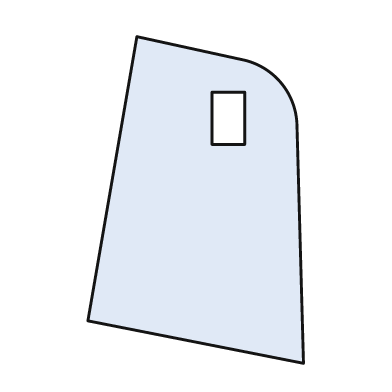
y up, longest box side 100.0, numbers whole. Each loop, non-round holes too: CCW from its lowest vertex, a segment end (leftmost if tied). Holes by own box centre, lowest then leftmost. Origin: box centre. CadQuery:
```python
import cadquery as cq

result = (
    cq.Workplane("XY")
    .moveTo(33.0, -50.0)
    .lineTo(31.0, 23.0)
    .threePointArc((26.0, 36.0), (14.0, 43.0))
    .lineTo(-18.0, 50.0)
    .lineTo(-33.0, -37.0)
    .close()
    .moveTo(5.0, 17.0)
    .lineTo(15.0, 17.0)
    .lineTo(15.0, 33.0)
    .lineTo(5.0, 33.0)
    .close()
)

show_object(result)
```